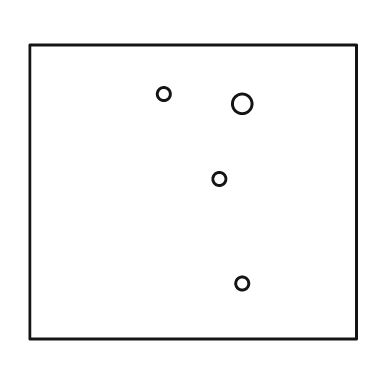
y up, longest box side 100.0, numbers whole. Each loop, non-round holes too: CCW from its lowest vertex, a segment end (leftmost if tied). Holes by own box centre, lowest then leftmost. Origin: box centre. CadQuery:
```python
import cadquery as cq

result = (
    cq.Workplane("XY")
    .moveTo(-50.0, -45.0)
    .lineTo(50.0, -45.0)
    .lineTo(50.0, 45.0)
    .lineTo(-50.0, 45.0)
    .close()
    .moveTo(15.0, -28.0)
    .circle(2.0)
    .moveTo(8.0, 4.0)
    .circle(2.0)
    .moveTo(15.0, 27.0)
    .circle(3.0)
    .moveTo(-9.0, 30.0)
    .circle(2.0)
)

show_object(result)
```